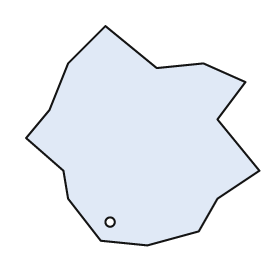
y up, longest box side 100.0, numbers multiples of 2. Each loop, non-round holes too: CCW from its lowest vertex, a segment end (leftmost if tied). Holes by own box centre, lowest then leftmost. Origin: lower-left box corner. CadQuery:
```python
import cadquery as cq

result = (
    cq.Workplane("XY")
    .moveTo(52.0, 0.0)
    .lineTo(74.0, 6.0)
    .lineTo(82.0, 20.0)
    .lineTo(100.0, 32.0)
    .lineTo(82.0, 54.0)
    .lineTo(94.0, 70.0)
    .lineTo(76.0, 78.0)
    .lineTo(56.0, 76.0)
    .lineTo(34.0, 94.0)
    .lineTo(18.0, 78.0)
    .lineTo(10.0, 58.0)
    .lineTo(0.0, 46.0)
    .lineTo(16.0, 32.0)
    .lineTo(18.0, 20.0)
    .lineTo(32.0, 2.0)
    .close()
    .moveTo(36.0, 10.0)
    .circle(2.0)
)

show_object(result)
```